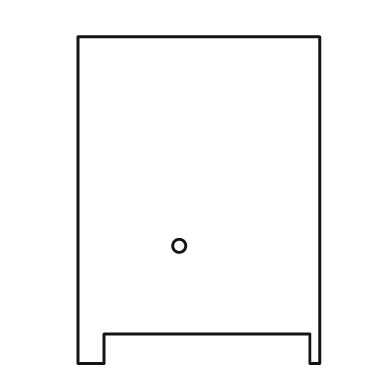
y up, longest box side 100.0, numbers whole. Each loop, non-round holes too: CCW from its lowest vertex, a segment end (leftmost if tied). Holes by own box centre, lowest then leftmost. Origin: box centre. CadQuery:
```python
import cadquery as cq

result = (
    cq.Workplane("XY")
    .moveTo(-37.0, -50.0)
    .lineTo(-29.0, -50.0)
    .lineTo(-29.0, -41.0)
    .lineTo(34.0, -41.0)
    .lineTo(34.0, -50.0)
    .lineTo(37.0, -50.0)
    .lineTo(37.0, 50.0)
    .lineTo(-37.0, 50.0)
    .close()
    .moveTo(-6.0, -14.0)
    .circle(2.0)
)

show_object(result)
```